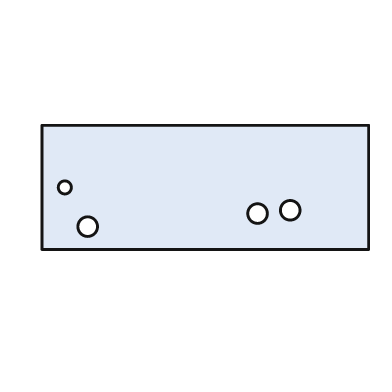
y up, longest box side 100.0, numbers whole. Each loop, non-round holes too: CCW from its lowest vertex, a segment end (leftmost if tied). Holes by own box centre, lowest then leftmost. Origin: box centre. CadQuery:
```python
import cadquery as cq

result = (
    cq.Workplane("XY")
    .moveTo(-50.0, -19.0)
    .lineTo(50.0, -19.0)
    .lineTo(50.0, 19.0)
    .lineTo(-50.0, 19.0)
    .close()
    .moveTo(-36.0, -12.0)
    .circle(3.0)
    .moveTo(16.0, -8.0)
    .circle(3.0)
    .moveTo(26.0, -7.0)
    .circle(3.0)
    .moveTo(-43.0, 0.0)
    .circle(2.0)
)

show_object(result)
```